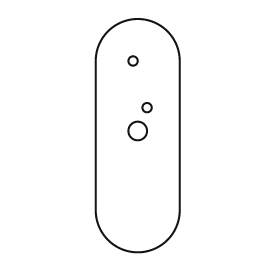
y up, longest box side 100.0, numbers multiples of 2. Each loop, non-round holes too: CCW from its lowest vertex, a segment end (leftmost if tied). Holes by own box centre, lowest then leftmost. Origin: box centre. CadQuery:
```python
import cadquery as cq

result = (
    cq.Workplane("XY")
    .moveTo(-18.0, -32.0)
    .threePointArc((0.0, -50.0), (18.0, -32.0))
    .lineTo(18.0, 32.0)
    .threePointArc((0.0, 50.0), (-18.0, 32.0))
    .close()
    .moveTo(0.0, 2.0)
    .circle(4.0)
    .moveTo(4.0, 12.0)
    .circle(2.0)
    .moveTo(-2.0, 32.0)
    .circle(2.0)
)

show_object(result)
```